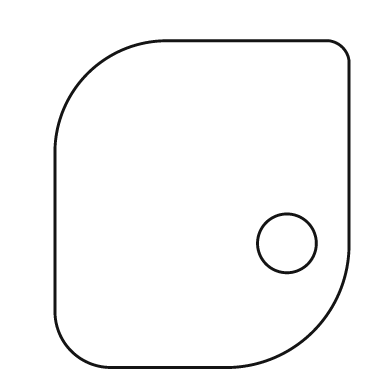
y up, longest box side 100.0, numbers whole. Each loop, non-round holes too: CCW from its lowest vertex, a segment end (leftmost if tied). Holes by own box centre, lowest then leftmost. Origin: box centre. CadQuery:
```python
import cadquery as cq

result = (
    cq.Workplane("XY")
    .moveTo(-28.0, -50.0)
    .lineTo(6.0, -50.0)
    .threePointArc((34.0, -39.0), (45.0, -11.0))
    .lineTo(45.0, 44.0)
    .threePointArc((43.0, 48.0), (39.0, 50.0))
    .lineTo(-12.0, 50.0)
    .threePointArc((-35.0, 40.0), (-45.0, 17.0))
    .lineTo(-45.0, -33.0)
    .threePointArc((-40.0, -45.0), (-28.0, -50.0))
    .close()
    .moveTo(26.0, -12.0)
    .circle(9.0)
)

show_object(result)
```